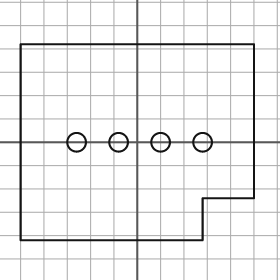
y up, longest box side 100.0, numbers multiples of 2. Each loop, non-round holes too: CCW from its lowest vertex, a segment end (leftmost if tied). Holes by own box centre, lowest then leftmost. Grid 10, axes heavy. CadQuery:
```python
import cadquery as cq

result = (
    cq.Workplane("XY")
    .moveTo(-50.0, -42.0)
    .lineTo(28.0, -42.0)
    .lineTo(28.0, -24.0)
    .lineTo(50.0, -24.0)
    .lineTo(50.0, 42.0)
    .lineTo(-50.0, 42.0)
    .close()
    .moveTo(-26.0, 0.0)
    .circle(4.0)
    .moveTo(-8.0, 0.0)
    .circle(4.0)
    .moveTo(10.0, 0.0)
    .circle(4.0)
    .moveTo(28.0, 0.0)
    .circle(4.0)
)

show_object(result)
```